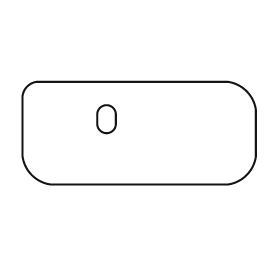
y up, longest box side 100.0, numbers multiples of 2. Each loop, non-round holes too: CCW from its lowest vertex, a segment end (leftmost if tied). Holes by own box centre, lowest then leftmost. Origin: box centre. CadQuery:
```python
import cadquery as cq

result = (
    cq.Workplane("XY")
    .moveTo(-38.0, -22.0)
    .lineTo(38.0, -22.0)
    .threePointArc((46.0, -18.0), (50.0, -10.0))
    .lineTo(50.0, 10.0)
    .threePointArc((46.0, 18.0), (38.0, 22.0))
    .lineTo(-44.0, 22.0)
    .threePointArc((-48.0, 20.0), (-50.0, 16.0))
    .lineTo(-50.0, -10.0)
    .threePointArc((-46.0, -18.0), (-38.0, -22.0))
    .close()
    .moveTo(-18.0, 4.0)
    .threePointArc((-14.0, 0.0), (-10.0, 4.0))
    .lineTo(-10.0, 8.0)
    .threePointArc((-14.0, 12.0), (-18.0, 8.0))
    .close()
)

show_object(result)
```